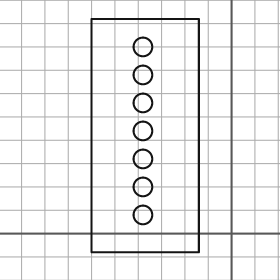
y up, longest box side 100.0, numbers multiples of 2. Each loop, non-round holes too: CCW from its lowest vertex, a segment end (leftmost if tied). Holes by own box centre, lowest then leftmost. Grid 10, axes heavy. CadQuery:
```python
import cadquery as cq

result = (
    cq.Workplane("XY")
    .moveTo(-60.0, -8.0)
    .lineTo(-14.0, -8.0)
    .lineTo(-14.0, 92.0)
    .lineTo(-60.0, 92.0)
    .close()
    .moveTo(-38.0, 8.0)
    .circle(4.0)
    .moveTo(-38.0, 20.0)
    .circle(4.0)
    .moveTo(-38.0, 32.0)
    .circle(4.0)
    .moveTo(-38.0, 44.0)
    .circle(4.0)
    .moveTo(-38.0, 56.0)
    .circle(4.0)
    .moveTo(-38.0, 68.0)
    .circle(4.0)
    .moveTo(-38.0, 80.0)
    .circle(4.0)
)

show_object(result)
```